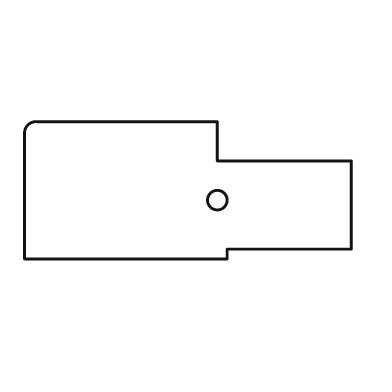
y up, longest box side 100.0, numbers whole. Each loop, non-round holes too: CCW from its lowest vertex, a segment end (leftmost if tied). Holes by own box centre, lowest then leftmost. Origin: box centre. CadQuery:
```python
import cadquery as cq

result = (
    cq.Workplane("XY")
    .moveTo(-50.0, -21.0)
    .lineTo(12.0, -21.0)
    .lineTo(12.0, -18.0)
    .lineTo(50.0, -18.0)
    .lineTo(50.0, 9.0)
    .lineTo(9.0, 9.0)
    .lineTo(9.0, 21.0)
    .lineTo(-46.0, 21.0)
    .threePointArc((-49.0, 20.0), (-50.0, 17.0))
    .close()
    .moveTo(9.0, -3.0)
    .circle(3.0)
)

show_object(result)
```